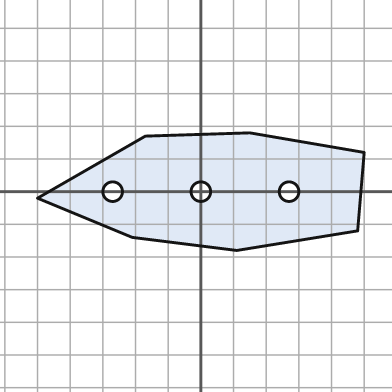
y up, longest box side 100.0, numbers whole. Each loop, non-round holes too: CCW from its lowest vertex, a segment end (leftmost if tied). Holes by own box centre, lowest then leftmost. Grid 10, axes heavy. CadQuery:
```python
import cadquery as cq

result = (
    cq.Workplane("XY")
    .moveTo(11.0, -18.0)
    .lineTo(48.0, -12.0)
    .lineTo(50.0, 12.0)
    .lineTo(15.0, 18.0)
    .lineTo(-17.0, 17.0)
    .lineTo(-50.0, -2.0)
    .lineTo(-21.0, -14.0)
    .close()
    .moveTo(-27.0, 0.0)
    .circle(3.0)
    .moveTo(0.0, 0.0)
    .circle(3.0)
    .moveTo(27.0, 0.0)
    .circle(3.0)
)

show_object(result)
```